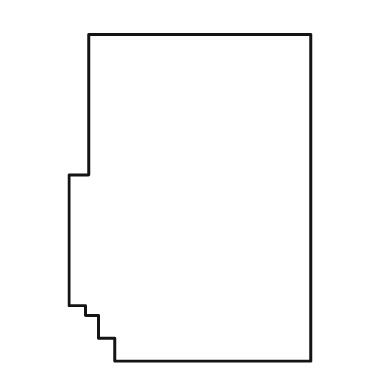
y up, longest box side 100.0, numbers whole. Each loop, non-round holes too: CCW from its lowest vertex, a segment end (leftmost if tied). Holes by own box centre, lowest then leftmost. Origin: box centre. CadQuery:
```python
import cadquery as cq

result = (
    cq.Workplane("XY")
    .moveTo(-23.0, -50.0)
    .lineTo(37.0, -50.0)
    .lineTo(37.0, 50.0)
    .lineTo(-31.0, 50.0)
    .lineTo(-31.0, 7.0)
    .lineTo(-37.0, 7.0)
    .lineTo(-37.0, -33.0)
    .lineTo(-32.0, -33.0)
    .lineTo(-32.0, -36.0)
    .lineTo(-28.0, -36.0)
    .lineTo(-28.0, -43.0)
    .lineTo(-23.0, -43.0)
    .close()
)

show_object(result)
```